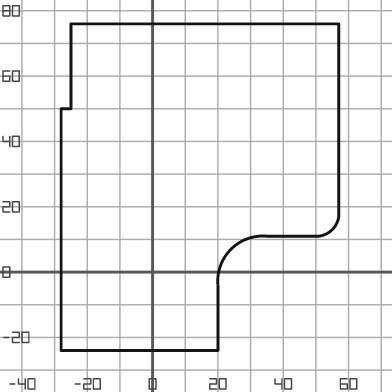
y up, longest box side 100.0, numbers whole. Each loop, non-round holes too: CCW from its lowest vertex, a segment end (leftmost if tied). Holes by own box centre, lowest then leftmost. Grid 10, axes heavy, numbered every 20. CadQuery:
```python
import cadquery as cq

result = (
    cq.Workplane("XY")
    .moveTo(-28.0, -24.0)
    .lineTo(20.0, -24.0)
    .lineTo(20.0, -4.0)
    .threePointArc((24.0, 7.0), (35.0, 11.0))
    .lineTo(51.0, 11.0)
    .threePointArc((55.0, 13.0), (57.0, 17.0))
    .lineTo(57.0, 76.0)
    .lineTo(-25.0, 76.0)
    .lineTo(-25.0, 50.0)
    .lineTo(-28.0, 50.0)
    .close()
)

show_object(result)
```